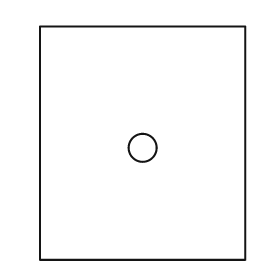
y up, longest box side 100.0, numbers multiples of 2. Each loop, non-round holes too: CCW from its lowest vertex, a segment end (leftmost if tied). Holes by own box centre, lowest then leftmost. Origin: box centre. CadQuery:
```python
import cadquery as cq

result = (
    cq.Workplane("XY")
    .moveTo(-44.0, -50.0)
    .lineTo(44.0, -50.0)
    .lineTo(44.0, 50.0)
    .lineTo(-44.0, 50.0)
    .close()
    .moveTo(0.0, -2.0)
    .circle(6.0)
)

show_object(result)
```